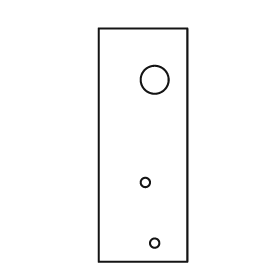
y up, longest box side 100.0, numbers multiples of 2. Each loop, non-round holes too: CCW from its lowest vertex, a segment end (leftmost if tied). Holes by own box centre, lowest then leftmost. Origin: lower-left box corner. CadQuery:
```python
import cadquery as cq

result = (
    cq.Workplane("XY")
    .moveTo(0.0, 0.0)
    .lineTo(38.0, 0.0)
    .lineTo(38.0, 100.0)
    .lineTo(0.0, 100.0)
    .close()
    .moveTo(24.0, 8.0)
    .circle(2.0)
    .moveTo(20.0, 34.0)
    .circle(2.0)
    .moveTo(24.0, 78.0)
    .circle(6.0)
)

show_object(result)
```